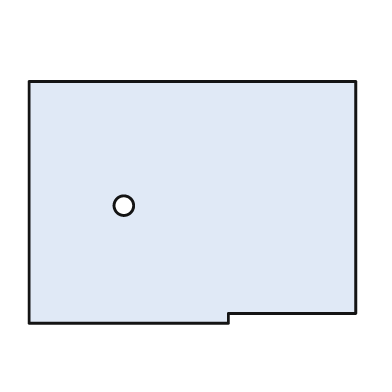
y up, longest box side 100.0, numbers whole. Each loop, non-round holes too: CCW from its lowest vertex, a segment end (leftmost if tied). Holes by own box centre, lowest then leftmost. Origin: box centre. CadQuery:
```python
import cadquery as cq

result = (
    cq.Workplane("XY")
    .moveTo(-50.0, -37.0)
    .lineTo(11.0, -37.0)
    .lineTo(11.0, -34.0)
    .lineTo(50.0, -34.0)
    .lineTo(50.0, 37.0)
    .lineTo(-50.0, 37.0)
    .close()
    .moveTo(-21.0, -1.0)
    .circle(3.0)
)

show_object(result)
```